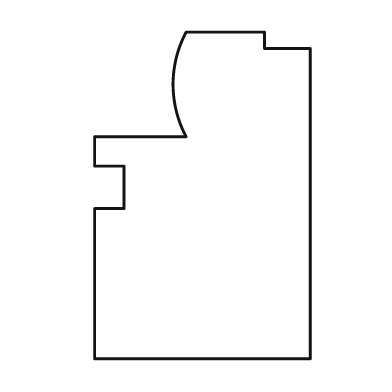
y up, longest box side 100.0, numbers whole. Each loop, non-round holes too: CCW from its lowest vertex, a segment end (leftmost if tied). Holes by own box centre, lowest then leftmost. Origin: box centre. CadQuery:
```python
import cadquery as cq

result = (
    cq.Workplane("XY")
    .moveTo(-33.0, -50.0)
    .lineTo(33.0, -50.0)
    .lineTo(33.0, 45.0)
    .lineTo(19.0, 45.0)
    .lineTo(19.0, 50.0)
    .lineTo(-5.0, 50.0)
    .threePointArc((-9.0, 34.0), (-5.0, 18.0))
    .lineTo(-33.0, 18.0)
    .lineTo(-33.0, 9.0)
    .lineTo(-24.0, 9.0)
    .lineTo(-24.0, -4.0)
    .lineTo(-33.0, -4.0)
    .close()
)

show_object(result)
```